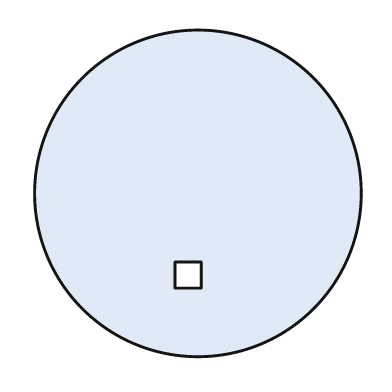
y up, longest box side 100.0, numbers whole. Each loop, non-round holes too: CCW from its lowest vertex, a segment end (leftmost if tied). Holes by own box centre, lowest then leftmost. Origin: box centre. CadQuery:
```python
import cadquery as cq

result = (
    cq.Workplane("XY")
    .moveTo(0.0, 0.0)
    .circle(50.0)
    .moveTo(-7.0, -29.0)
    .lineTo(1.0, -29.0)
    .lineTo(1.0, -21.0)
    .lineTo(-7.0, -21.0)
    .close()
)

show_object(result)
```